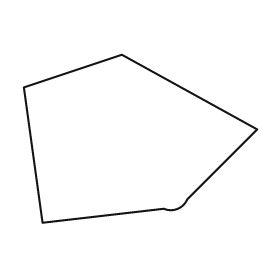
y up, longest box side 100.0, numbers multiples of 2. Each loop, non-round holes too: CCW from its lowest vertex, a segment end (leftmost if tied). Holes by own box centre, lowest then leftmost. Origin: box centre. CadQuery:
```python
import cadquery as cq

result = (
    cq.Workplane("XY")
    .moveTo(-42.0, -36.0)
    .lineTo(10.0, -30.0)
    .threePointArc((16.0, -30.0), (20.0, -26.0))
    .lineTo(50.0, 4.0)
    .lineTo(-8.0, 36.0)
    .lineTo(-50.0, 22.0)
    .close()
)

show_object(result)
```